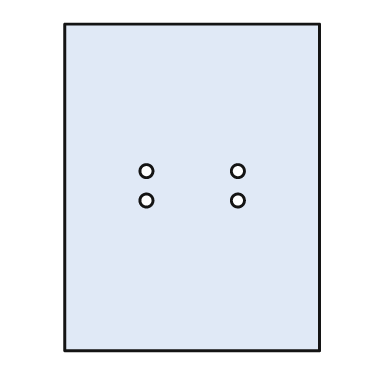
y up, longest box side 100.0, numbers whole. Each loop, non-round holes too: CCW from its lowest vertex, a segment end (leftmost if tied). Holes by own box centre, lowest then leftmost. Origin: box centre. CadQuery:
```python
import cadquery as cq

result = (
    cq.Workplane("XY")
    .moveTo(-39.0, -50.0)
    .lineTo(39.0, -50.0)
    .lineTo(39.0, 50.0)
    .lineTo(-39.0, 50.0)
    .close()
    .moveTo(-14.0, -4.0)
    .circle(2.0)
    .moveTo(14.0, -4.0)
    .circle(2.0)
    .moveTo(-14.0, 5.0)
    .circle(2.0)
    .moveTo(14.0, 5.0)
    .circle(2.0)
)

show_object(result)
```